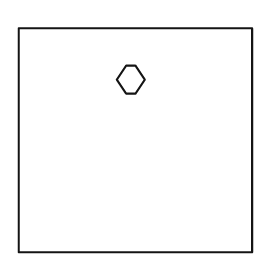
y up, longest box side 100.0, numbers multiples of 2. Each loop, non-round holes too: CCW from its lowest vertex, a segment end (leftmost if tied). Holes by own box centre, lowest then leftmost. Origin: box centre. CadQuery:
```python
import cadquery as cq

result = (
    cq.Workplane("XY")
    .moveTo(-50.0, -48.0)
    .lineTo(50.0, -48.0)
    .lineTo(50.0, 48.0)
    .lineTo(-50.0, 48.0)
    .close()
    .moveTo(-4.0, 20.0)
    .lineTo(0.0, 20.0)
    .lineTo(4.0, 26.0)
    .lineTo(0.0, 32.0)
    .lineTo(-4.0, 32.0)
    .lineTo(-8.0, 26.0)
    .close()
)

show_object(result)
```